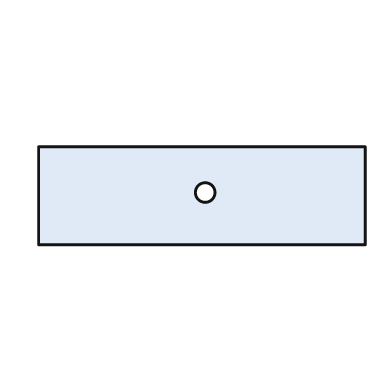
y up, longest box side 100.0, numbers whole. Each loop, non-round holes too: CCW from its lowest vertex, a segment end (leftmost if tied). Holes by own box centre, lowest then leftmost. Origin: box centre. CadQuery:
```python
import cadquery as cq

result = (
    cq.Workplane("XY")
    .moveTo(-50.0, -15.0)
    .lineTo(50.0, -15.0)
    .lineTo(50.0, 15.0)
    .lineTo(-50.0, 15.0)
    .close()
    .moveTo(1.0, 1.0)
    .circle(3.0)
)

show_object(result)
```